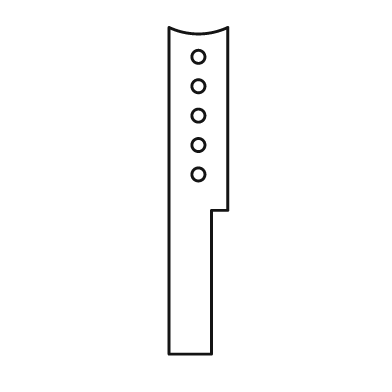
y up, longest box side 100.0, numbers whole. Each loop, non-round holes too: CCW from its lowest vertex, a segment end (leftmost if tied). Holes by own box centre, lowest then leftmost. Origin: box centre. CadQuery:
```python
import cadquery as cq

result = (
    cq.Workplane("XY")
    .moveTo(-9.0, -50.0)
    .lineTo(4.0, -50.0)
    .lineTo(4.0, -6.0)
    .lineTo(9.0, -6.0)
    .lineTo(9.0, 50.0)
    .threePointArc((0.0, 48.0), (-9.0, 50.0))
    .close()
    .moveTo(0.0, 5.0)
    .circle(2.0)
    .moveTo(0.0, 14.0)
    .circle(2.0)
    .moveTo(0.0, 23.0)
    .circle(2.0)
    .moveTo(0.0, 32.0)
    .circle(2.0)
    .moveTo(0.0, 41.0)
    .circle(2.0)
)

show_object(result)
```